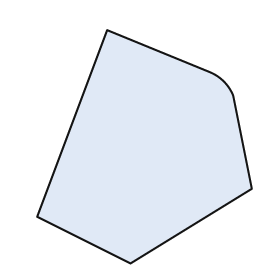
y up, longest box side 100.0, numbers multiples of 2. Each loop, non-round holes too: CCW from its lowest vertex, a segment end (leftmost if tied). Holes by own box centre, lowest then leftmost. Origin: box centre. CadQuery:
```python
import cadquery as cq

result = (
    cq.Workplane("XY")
    .moveTo(-6.0, -50.0)
    .lineTo(46.0, -18.0)
    .lineTo(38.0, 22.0)
    .threePointArc((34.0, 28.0), (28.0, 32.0))
    .lineTo(-16.0, 50.0)
    .lineTo(-46.0, -30.0)
    .close()
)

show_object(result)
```